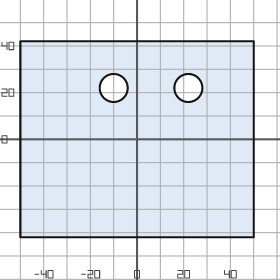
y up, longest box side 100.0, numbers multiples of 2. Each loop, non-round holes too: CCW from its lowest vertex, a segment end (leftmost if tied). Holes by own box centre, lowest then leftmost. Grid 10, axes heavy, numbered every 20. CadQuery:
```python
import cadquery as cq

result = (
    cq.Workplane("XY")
    .moveTo(-50.0, -42.0)
    .lineTo(50.0, -42.0)
    .lineTo(50.0, 42.0)
    .lineTo(-50.0, 42.0)
    .close()
    .moveTo(-10.0, 22.0)
    .circle(6.0)
    .moveTo(22.0, 22.0)
    .circle(6.0)
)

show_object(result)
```